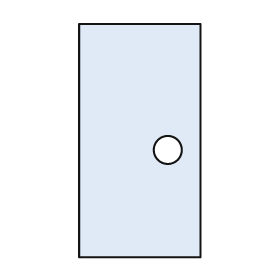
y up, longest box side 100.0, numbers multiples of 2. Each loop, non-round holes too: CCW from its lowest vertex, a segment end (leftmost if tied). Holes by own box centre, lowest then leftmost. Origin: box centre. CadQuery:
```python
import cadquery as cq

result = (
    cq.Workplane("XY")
    .moveTo(-26.0, -50.0)
    .lineTo(26.0, -50.0)
    .lineTo(26.0, 50.0)
    .lineTo(-26.0, 50.0)
    .close()
    .moveTo(12.0, -4.0)
    .circle(6.0)
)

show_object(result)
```